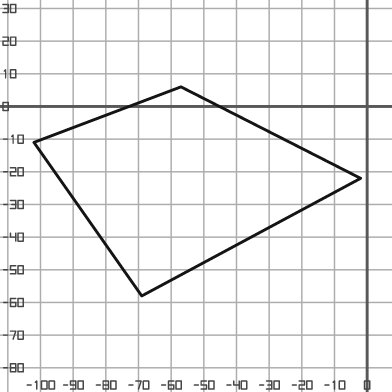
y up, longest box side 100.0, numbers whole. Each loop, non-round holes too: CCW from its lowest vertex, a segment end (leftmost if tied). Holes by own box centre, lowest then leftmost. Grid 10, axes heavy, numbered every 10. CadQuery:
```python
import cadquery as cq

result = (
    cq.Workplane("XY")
    .moveTo(-69.0, -58.0)
    .lineTo(-2.0, -22.0)
    .lineTo(-57.0, 6.0)
    .lineTo(-102.0, -11.0)
    .close()
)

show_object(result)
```